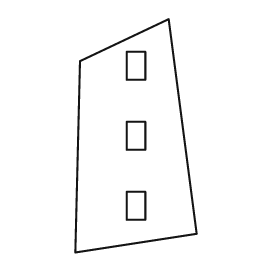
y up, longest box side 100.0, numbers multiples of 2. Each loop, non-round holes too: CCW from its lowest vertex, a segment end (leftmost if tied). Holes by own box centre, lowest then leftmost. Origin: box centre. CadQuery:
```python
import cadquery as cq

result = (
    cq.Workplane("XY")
    .moveTo(-26.0, -50.0)
    .lineTo(26.0, -42.0)
    .lineTo(14.0, 50.0)
    .lineTo(-24.0, 32.0)
    .close()
    .moveTo(-4.0, -36.0)
    .lineTo(4.0, -36.0)
    .lineTo(4.0, -24.0)
    .lineTo(-4.0, -24.0)
    .close()
    .moveTo(-4.0, -6.0)
    .lineTo(4.0, -6.0)
    .lineTo(4.0, 6.0)
    .lineTo(-4.0, 6.0)
    .close()
    .moveTo(-4.0, 24.0)
    .lineTo(4.0, 24.0)
    .lineTo(4.0, 36.0)
    .lineTo(-4.0, 36.0)
    .close()
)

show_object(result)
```